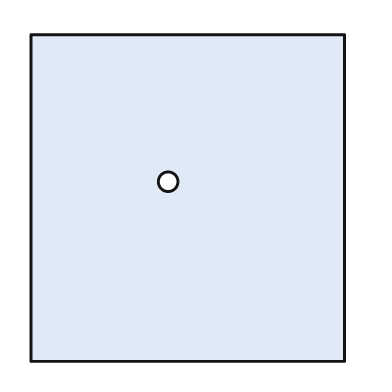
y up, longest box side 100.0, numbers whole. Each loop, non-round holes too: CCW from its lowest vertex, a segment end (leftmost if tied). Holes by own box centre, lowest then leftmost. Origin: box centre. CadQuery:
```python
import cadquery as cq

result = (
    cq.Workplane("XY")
    .moveTo(-48.0, -50.0)
    .lineTo(48.0, -50.0)
    .lineTo(48.0, 50.0)
    .lineTo(-48.0, 50.0)
    .close()
    .moveTo(-6.0, 5.0)
    .circle(3.0)
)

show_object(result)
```